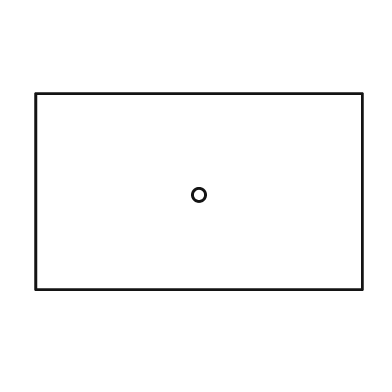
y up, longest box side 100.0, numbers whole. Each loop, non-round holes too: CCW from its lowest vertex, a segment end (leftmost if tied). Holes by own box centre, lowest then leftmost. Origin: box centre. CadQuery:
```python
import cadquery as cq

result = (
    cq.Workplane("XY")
    .moveTo(-50.0, -30.0)
    .lineTo(50.0, -30.0)
    .lineTo(50.0, 30.0)
    .lineTo(-50.0, 30.0)
    .close()
    .moveTo(0.0, -1.0)
    .circle(2.0)
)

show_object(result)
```